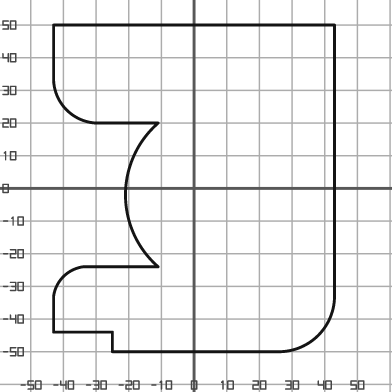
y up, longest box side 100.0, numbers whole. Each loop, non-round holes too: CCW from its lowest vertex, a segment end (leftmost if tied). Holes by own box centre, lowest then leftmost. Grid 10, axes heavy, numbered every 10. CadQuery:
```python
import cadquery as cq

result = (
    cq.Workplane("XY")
    .moveTo(-25.0, -50.0)
    .lineTo(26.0, -50.0)
    .threePointArc((38.0, -45.0), (43.0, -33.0))
    .lineTo(43.0, 50.0)
    .lineTo(-43.0, 50.0)
    .lineTo(-43.0, 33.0)
    .threePointArc((-39.0, 24.0), (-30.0, 20.0))
    .lineTo(-11.0, 20.0)
    .threePointArc((-21.0, -2.0), (-11.0, -24.0))
    .lineTo(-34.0, -24.0)
    .threePointArc((-40.0, -27.0), (-43.0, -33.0))
    .lineTo(-43.0, -44.0)
    .lineTo(-25.0, -44.0)
    .close()
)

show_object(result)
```